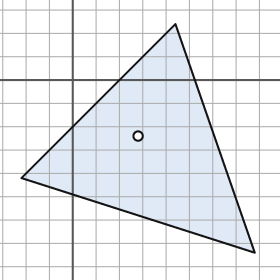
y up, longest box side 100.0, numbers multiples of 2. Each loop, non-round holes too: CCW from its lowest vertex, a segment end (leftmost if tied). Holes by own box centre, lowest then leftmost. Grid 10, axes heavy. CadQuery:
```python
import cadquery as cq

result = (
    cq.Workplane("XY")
    .moveTo(78.0, -74.0)
    .lineTo(44.0, 24.0)
    .lineTo(-22.0, -42.0)
    .close()
    .moveTo(28.0, -24.0)
    .circle(2.0)
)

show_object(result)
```